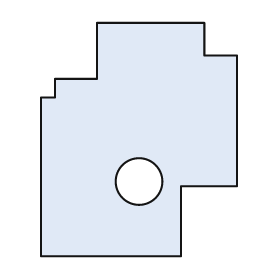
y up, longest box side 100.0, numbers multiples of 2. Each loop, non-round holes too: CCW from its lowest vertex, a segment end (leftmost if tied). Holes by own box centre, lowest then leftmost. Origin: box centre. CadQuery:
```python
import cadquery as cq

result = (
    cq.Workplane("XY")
    .moveTo(-42.0, -50.0)
    .lineTo(18.0, -50.0)
    .lineTo(18.0, -20.0)
    .lineTo(42.0, -20.0)
    .lineTo(42.0, 36.0)
    .lineTo(28.0, 36.0)
    .lineTo(28.0, 50.0)
    .lineTo(-18.0, 50.0)
    .lineTo(-18.0, 26.0)
    .lineTo(-36.0, 26.0)
    .lineTo(-36.0, 18.0)
    .lineTo(-42.0, 18.0)
    .close()
    .moveTo(0.0, -18.0)
    .circle(10.0)
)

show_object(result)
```